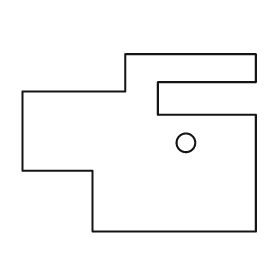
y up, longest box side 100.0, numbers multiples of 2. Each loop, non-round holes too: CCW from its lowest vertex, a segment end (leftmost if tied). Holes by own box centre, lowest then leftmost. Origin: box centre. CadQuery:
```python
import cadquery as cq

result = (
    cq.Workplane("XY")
    .moveTo(-20.0, -38.0)
    .lineTo(50.0, -38.0)
    .lineTo(50.0, 12.0)
    .lineTo(8.0, 12.0)
    .lineTo(8.0, 26.0)
    .lineTo(50.0, 26.0)
    .lineTo(50.0, 38.0)
    .lineTo(-6.0, 38.0)
    .lineTo(-6.0, 22.0)
    .lineTo(-50.0, 22.0)
    .lineTo(-50.0, -12.0)
    .lineTo(-20.0, -12.0)
    .close()
    .moveTo(20.0, 0.0)
    .circle(4.0)
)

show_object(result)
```